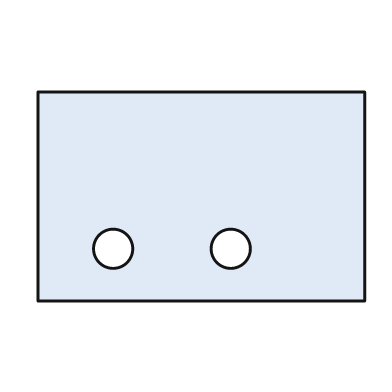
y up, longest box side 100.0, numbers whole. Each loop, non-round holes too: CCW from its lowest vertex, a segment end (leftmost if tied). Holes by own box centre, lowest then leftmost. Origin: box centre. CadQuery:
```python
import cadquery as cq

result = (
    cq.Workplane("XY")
    .moveTo(-50.0, -32.0)
    .lineTo(50.0, -32.0)
    .lineTo(50.0, 32.0)
    .lineTo(-50.0, 32.0)
    .close()
    .moveTo(-27.0, -16.0)
    .circle(6.0)
    .moveTo(9.0, -16.0)
    .circle(6.0)
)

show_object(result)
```